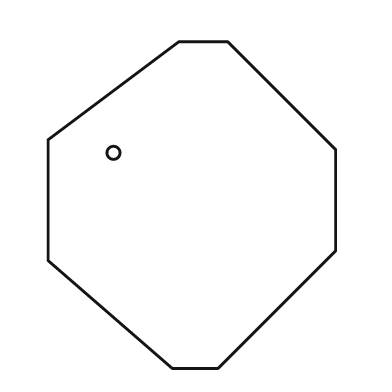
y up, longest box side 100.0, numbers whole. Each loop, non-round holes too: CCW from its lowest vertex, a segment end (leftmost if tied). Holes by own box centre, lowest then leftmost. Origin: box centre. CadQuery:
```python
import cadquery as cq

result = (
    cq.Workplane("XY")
    .moveTo(-6.0, -50.0)
    .lineTo(8.0, -50.0)
    .lineTo(44.0, -14.0)
    .lineTo(44.0, 17.0)
    .lineTo(11.0, 50.0)
    .lineTo(-4.0, 50.0)
    .lineTo(-44.0, 20.0)
    .lineTo(-44.0, -17.0)
    .close()
    .moveTo(-24.0, 16.0)
    .circle(2.0)
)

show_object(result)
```